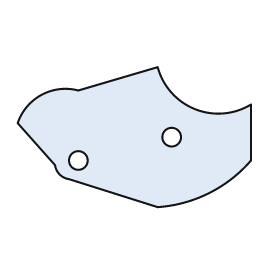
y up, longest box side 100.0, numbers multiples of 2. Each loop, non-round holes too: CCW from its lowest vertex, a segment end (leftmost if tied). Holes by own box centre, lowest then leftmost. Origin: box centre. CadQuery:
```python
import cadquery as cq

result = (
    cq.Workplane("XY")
    .moveTo(10.0, -30.0)
    .threePointArc((32.0, -24.0), (50.0, -10.0))
    .lineTo(50.0, 14.0)
    .threePointArc((26.0, 12.0), (10.0, 30.0))
    .lineTo(-24.0, 20.0)
    .threePointArc((-40.0, 18.0), (-50.0, 6.0))
    .lineTo(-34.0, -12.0)
    .threePointArc((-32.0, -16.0), (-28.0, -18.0))
    .close()
    .moveTo(-24.0, -10.0)
    .circle(4.0)
    .moveTo(16.0, 0.0)
    .circle(4.0)
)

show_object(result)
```